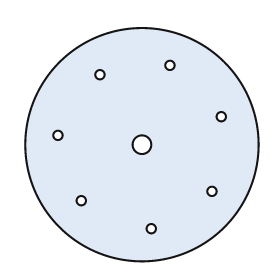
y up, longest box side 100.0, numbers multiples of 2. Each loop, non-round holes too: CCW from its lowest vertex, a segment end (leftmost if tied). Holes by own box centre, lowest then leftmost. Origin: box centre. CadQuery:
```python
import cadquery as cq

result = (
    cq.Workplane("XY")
    .moveTo(0.0, 0.0)
    .circle(50.0)
    .moveTo(4.0, -36.0)
    .circle(2.0)
    .moveTo(-26.0, -24.0)
    .circle(2.0)
    .moveTo(30.0, -20.0)
    .circle(2.0)
    .moveTo(0.0, 0.0)
    .circle(4.0)
    .moveTo(-36.0, 4.0)
    .circle(2.0)
    .moveTo(34.0, 12.0)
    .circle(2.0)
    .moveTo(-18.0, 30.0)
    .circle(2.0)
    .moveTo(12.0, 34.0)
    .circle(2.0)
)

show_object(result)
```